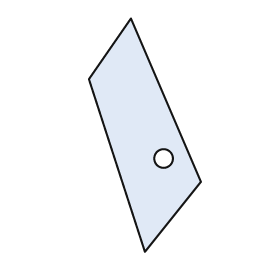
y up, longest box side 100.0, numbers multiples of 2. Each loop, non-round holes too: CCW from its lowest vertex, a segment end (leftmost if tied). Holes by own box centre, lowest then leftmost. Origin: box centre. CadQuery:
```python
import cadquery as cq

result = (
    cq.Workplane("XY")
    .moveTo(0.0, -50.0)
    .lineTo(24.0, -20.0)
    .lineTo(-6.0, 50.0)
    .lineTo(-24.0, 24.0)
    .close()
    .moveTo(8.0, -10.0)
    .circle(4.0)
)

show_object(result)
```